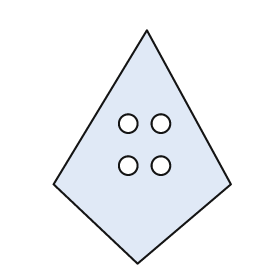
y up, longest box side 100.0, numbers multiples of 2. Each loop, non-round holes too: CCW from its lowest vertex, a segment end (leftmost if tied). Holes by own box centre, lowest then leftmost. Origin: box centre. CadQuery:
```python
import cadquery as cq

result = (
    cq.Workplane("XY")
    .moveTo(-2.0, -50.0)
    .lineTo(38.0, -16.0)
    .lineTo(2.0, 50.0)
    .lineTo(-38.0, -16.0)
    .close()
    .moveTo(-6.0, -8.0)
    .circle(4.0)
    .moveTo(8.0, -8.0)
    .circle(4.0)
    .moveTo(-6.0, 10.0)
    .circle(4.0)
    .moveTo(8.0, 10.0)
    .circle(4.0)
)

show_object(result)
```